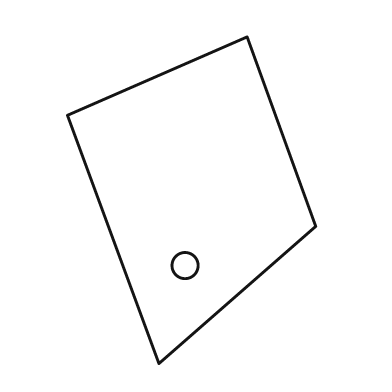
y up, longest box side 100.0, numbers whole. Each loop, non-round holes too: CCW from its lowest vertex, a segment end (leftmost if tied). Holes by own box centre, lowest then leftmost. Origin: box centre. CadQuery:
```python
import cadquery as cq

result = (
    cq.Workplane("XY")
    .moveTo(-10.0, -50.0)
    .lineTo(38.0, -8.0)
    .lineTo(17.0, 50.0)
    .lineTo(-38.0, 26.0)
    .close()
    .moveTo(-2.0, -20.0)
    .circle(4.0)
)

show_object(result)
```